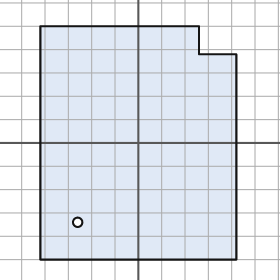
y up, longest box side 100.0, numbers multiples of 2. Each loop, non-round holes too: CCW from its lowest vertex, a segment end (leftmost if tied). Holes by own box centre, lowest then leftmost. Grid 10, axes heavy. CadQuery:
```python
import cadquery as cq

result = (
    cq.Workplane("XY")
    .moveTo(-42.0, -50.0)
    .lineTo(42.0, -50.0)
    .lineTo(42.0, 38.0)
    .lineTo(26.0, 38.0)
    .lineTo(26.0, 50.0)
    .lineTo(-42.0, 50.0)
    .close()
    .moveTo(-26.0, -34.0)
    .circle(2.0)
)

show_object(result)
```